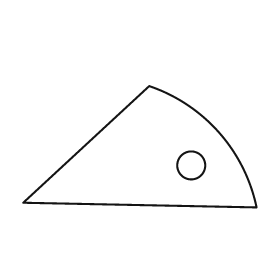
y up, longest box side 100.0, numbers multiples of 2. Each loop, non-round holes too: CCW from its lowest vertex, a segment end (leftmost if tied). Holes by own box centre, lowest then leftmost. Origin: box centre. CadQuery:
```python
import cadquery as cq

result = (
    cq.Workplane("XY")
    .moveTo(50.0, -26.0)
    .threePointArc((34.0, 6.0), (4.0, 26.0))
    .lineTo(-50.0, -24.0)
    .close()
    .moveTo(22.0, -8.0)
    .circle(6.0)
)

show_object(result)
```